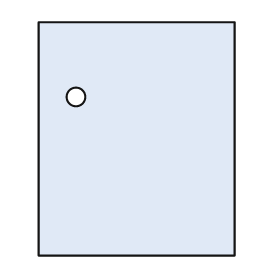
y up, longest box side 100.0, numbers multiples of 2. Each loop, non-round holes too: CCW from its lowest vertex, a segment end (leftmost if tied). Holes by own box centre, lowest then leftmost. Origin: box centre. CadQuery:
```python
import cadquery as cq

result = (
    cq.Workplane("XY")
    .moveTo(-42.0, -50.0)
    .lineTo(42.0, -50.0)
    .lineTo(42.0, 50.0)
    .lineTo(-42.0, 50.0)
    .close()
    .moveTo(-26.0, 18.0)
    .circle(4.0)
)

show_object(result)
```